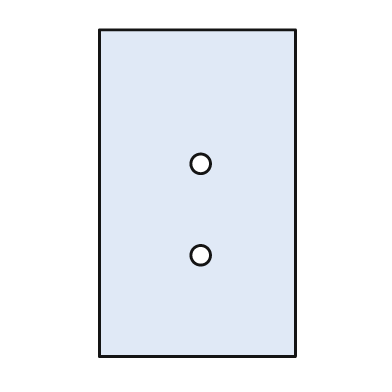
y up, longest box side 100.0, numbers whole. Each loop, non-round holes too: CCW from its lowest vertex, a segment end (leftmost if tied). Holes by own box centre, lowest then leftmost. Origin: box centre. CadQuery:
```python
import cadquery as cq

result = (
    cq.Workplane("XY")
    .moveTo(-30.0, -50.0)
    .lineTo(30.0, -50.0)
    .lineTo(30.0, 50.0)
    .lineTo(-30.0, 50.0)
    .close()
    .moveTo(1.0, -19.0)
    .circle(3.0)
    .moveTo(1.0, 9.0)
    .circle(3.0)
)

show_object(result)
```